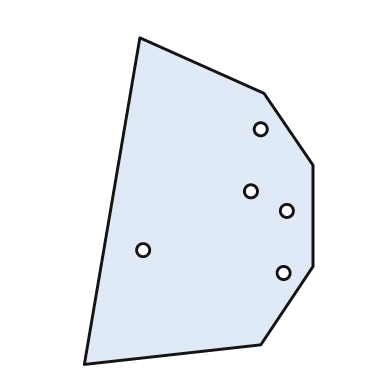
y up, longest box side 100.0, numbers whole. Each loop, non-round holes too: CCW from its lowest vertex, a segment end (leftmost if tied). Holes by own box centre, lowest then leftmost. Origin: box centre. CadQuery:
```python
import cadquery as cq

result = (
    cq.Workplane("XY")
    .moveTo(-35.0, -50.0)
    .lineTo(19.0, -44.0)
    .lineTo(35.0, -20.0)
    .lineTo(35.0, 11.0)
    .lineTo(20.0, 33.0)
    .lineTo(-18.0, 50.0)
    .close()
    .moveTo(26.0, -22.0)
    .circle(2.0)
    .moveTo(-17.0, -15.0)
    .circle(2.0)
    .moveTo(27.0, -3.0)
    .circle(2.0)
    .moveTo(16.0, 3.0)
    .circle(2.0)
    .moveTo(19.0, 22.0)
    .circle(2.0)
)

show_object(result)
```